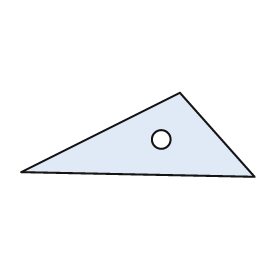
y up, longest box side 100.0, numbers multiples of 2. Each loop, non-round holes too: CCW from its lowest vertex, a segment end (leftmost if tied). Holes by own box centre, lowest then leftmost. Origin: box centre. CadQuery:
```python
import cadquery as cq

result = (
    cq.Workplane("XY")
    .moveTo(50.0, -18.0)
    .lineTo(18.0, 18.0)
    .lineTo(-50.0, -16.0)
    .close()
    .moveTo(10.0, -2.0)
    .circle(4.0)
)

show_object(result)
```